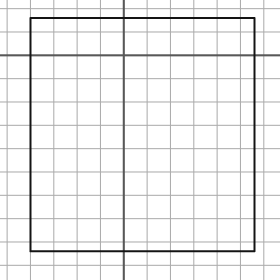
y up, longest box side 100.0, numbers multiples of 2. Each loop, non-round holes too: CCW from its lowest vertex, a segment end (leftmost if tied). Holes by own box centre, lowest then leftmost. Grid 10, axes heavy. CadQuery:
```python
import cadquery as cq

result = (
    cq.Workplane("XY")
    .moveTo(-40.0, -84.0)
    .lineTo(56.0, -84.0)
    .lineTo(56.0, 16.0)
    .lineTo(-40.0, 16.0)
    .close()
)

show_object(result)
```